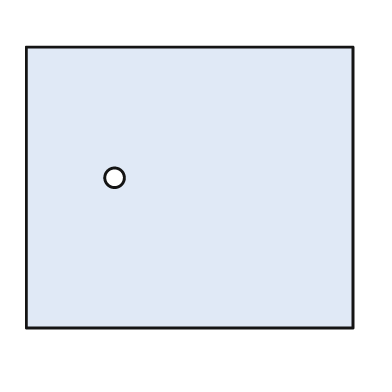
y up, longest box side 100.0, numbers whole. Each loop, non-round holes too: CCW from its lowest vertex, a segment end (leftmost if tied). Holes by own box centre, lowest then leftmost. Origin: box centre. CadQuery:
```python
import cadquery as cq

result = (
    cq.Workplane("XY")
    .moveTo(-50.0, -43.0)
    .lineTo(50.0, -43.0)
    .lineTo(50.0, 43.0)
    .lineTo(-50.0, 43.0)
    .close()
    .moveTo(-23.0, 3.0)
    .circle(3.0)
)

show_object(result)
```